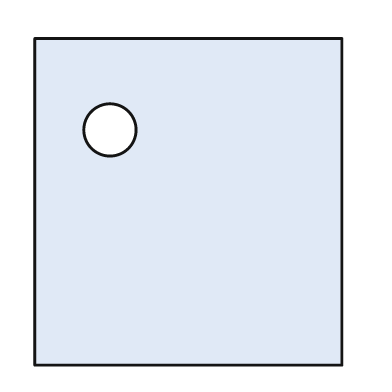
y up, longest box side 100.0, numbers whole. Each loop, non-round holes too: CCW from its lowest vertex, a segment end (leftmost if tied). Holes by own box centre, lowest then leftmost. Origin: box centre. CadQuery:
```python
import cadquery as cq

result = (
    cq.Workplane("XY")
    .moveTo(-47.0, -50.0)
    .lineTo(47.0, -50.0)
    .lineTo(47.0, 50.0)
    .lineTo(-47.0, 50.0)
    .close()
    .moveTo(-24.0, 22.0)
    .circle(8.0)
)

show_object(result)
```